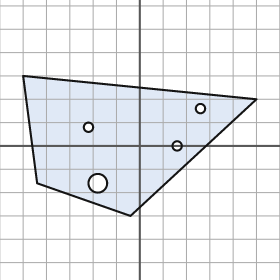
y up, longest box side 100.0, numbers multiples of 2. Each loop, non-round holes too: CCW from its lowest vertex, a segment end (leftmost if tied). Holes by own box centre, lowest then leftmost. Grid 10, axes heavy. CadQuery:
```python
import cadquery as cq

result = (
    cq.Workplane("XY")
    .moveTo(-4.0, -30.0)
    .lineTo(50.0, 20.0)
    .lineTo(-50.0, 30.0)
    .lineTo(-44.0, -16.0)
    .close()
    .moveTo(-18.0, -16.0)
    .circle(4.0)
    .moveTo(16.0, 0.0)
    .circle(2.0)
    .moveTo(-22.0, 8.0)
    .circle(2.0)
    .moveTo(26.0, 16.0)
    .circle(2.0)
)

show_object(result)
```